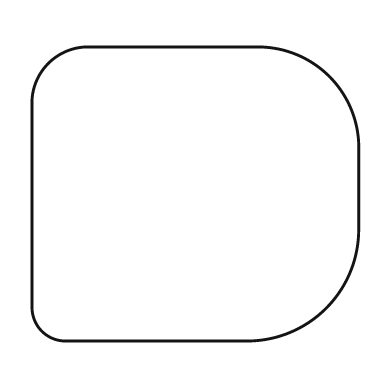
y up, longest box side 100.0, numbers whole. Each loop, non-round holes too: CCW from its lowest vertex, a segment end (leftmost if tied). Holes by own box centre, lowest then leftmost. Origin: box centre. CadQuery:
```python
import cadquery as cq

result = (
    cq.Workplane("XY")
    .moveTo(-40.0, -45.0)
    .lineTo(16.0, -45.0)
    .threePointArc((40.0, -35.0), (50.0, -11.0))
    .lineTo(50.0, 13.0)
    .threePointArc((41.0, 36.0), (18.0, 45.0))
    .lineTo(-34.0, 45.0)
    .threePointArc((-45.0, 40.0), (-50.0, 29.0))
    .lineTo(-50.0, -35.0)
    .threePointArc((-47.0, -42.0), (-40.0, -45.0))
    .close()
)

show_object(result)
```